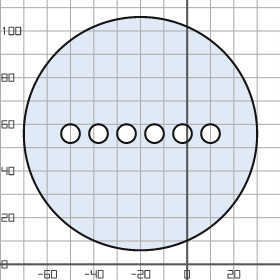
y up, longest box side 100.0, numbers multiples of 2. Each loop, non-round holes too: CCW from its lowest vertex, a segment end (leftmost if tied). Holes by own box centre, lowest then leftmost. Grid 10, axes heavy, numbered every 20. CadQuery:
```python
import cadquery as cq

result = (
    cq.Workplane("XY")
    .moveTo(-20.0, 56.0)
    .circle(50.0)
    .moveTo(-50.0, 56.0)
    .circle(4.0)
    .moveTo(-38.0, 56.0)
    .circle(4.0)
    .moveTo(-26.0, 56.0)
    .circle(4.0)
    .moveTo(-14.0, 56.0)
    .circle(4.0)
    .moveTo(-2.0, 56.0)
    .circle(4.0)
    .moveTo(10.0, 56.0)
    .circle(4.0)
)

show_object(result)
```